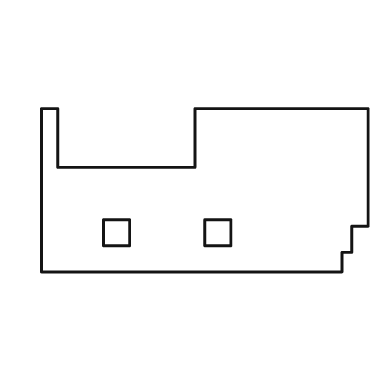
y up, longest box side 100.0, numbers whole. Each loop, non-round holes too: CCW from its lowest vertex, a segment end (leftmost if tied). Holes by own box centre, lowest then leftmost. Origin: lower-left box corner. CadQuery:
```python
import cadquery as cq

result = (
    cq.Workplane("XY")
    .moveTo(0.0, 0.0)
    .lineTo(92.0, 0.0)
    .lineTo(92.0, 6.0)
    .lineTo(95.0, 6.0)
    .lineTo(95.0, 14.0)
    .lineTo(100.0, 14.0)
    .lineTo(100.0, 50.0)
    .lineTo(47.0, 50.0)
    .lineTo(47.0, 32.0)
    .lineTo(5.0, 32.0)
    .lineTo(5.0, 50.0)
    .lineTo(0.0, 50.0)
    .close()
    .moveTo(19.0, 8.0)
    .lineTo(27.0, 8.0)
    .lineTo(27.0, 16.0)
    .lineTo(19.0, 16.0)
    .close()
    .moveTo(50.0, 8.0)
    .lineTo(58.0, 8.0)
    .lineTo(58.0, 16.0)
    .lineTo(50.0, 16.0)
    .close()
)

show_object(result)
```